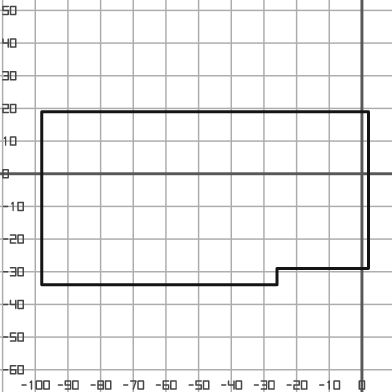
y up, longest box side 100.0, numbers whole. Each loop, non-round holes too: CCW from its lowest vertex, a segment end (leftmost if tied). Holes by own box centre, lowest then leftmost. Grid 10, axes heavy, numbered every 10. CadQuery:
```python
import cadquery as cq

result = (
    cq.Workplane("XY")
    .moveTo(-98.0, -34.0)
    .lineTo(-26.0, -34.0)
    .lineTo(-26.0, -29.0)
    .lineTo(2.0, -29.0)
    .lineTo(2.0, 19.0)
    .lineTo(-98.0, 19.0)
    .close()
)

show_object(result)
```